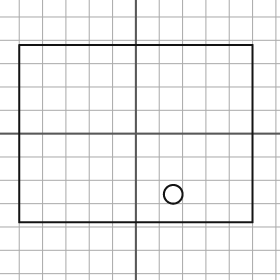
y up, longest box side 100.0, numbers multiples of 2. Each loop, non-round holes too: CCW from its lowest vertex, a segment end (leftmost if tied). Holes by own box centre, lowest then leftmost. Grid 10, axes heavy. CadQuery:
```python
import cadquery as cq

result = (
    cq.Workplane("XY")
    .moveTo(-50.0, -38.0)
    .lineTo(50.0, -38.0)
    .lineTo(50.0, 38.0)
    .lineTo(-50.0, 38.0)
    .close()
    .moveTo(16.0, -26.0)
    .circle(4.0)
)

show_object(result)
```